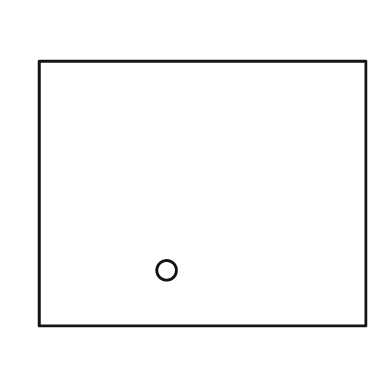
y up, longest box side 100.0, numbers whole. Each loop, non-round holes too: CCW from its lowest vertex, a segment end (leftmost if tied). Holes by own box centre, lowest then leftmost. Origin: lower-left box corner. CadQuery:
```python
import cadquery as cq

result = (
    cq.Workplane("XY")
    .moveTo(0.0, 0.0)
    .lineTo(100.0, 0.0)
    .lineTo(100.0, 81.0)
    .lineTo(0.0, 81.0)
    .close()
    .moveTo(39.0, 17.0)
    .circle(3.0)
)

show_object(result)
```